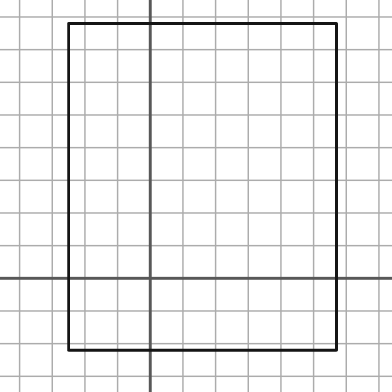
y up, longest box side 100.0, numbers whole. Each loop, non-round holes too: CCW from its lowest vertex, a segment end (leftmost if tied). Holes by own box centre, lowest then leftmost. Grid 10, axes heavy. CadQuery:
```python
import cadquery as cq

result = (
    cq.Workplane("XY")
    .moveTo(-25.0, -22.0)
    .lineTo(57.0, -22.0)
    .lineTo(57.0, 78.0)
    .lineTo(-25.0, 78.0)
    .close()
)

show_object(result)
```